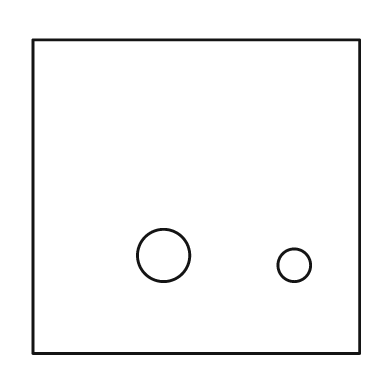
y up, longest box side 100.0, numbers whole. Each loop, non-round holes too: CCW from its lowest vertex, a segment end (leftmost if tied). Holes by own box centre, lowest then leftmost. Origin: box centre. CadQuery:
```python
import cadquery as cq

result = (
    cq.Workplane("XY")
    .moveTo(-50.0, -48.0)
    .lineTo(50.0, -48.0)
    .lineTo(50.0, 48.0)
    .lineTo(-50.0, 48.0)
    .close()
    .moveTo(30.0, -21.0)
    .circle(5.0)
    .moveTo(-10.0, -18.0)
    .circle(8.0)
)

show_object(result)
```